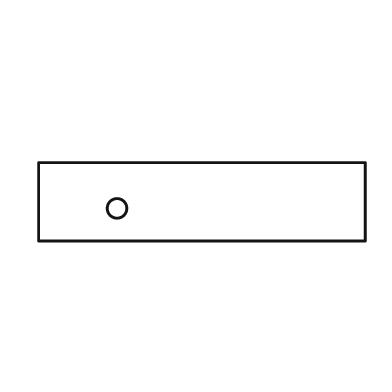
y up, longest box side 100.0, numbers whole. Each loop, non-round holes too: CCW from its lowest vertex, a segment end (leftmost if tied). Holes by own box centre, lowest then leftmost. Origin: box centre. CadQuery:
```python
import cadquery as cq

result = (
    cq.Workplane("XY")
    .moveTo(-50.0, -12.0)
    .lineTo(50.0, -12.0)
    .lineTo(50.0, 12.0)
    .lineTo(-50.0, 12.0)
    .close()
    .moveTo(-26.0, -2.0)
    .circle(3.0)
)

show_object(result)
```